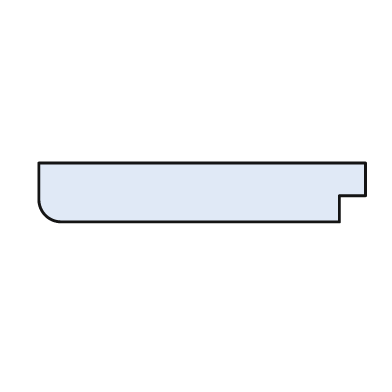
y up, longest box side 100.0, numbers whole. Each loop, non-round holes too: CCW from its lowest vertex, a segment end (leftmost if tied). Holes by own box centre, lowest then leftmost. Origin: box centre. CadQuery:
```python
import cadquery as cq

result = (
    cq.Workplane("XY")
    .moveTo(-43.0, -9.0)
    .lineTo(42.0, -9.0)
    .lineTo(42.0, -1.0)
    .lineTo(50.0, -1.0)
    .lineTo(50.0, 9.0)
    .lineTo(-50.0, 9.0)
    .lineTo(-50.0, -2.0)
    .threePointArc((-48.0, -7.0), (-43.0, -9.0))
    .close()
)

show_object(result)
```